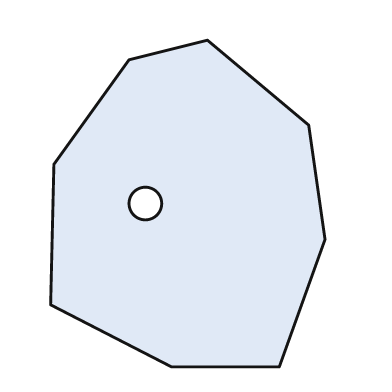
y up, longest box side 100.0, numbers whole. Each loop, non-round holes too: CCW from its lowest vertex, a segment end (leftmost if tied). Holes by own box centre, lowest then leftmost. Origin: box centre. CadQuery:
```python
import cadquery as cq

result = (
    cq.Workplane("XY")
    .moveTo(-5.0, -50.0)
    .lineTo(28.0, -50.0)
    .lineTo(42.0, -11.0)
    .lineTo(37.0, 24.0)
    .lineTo(6.0, 50.0)
    .lineTo(-18.0, 44.0)
    .lineTo(-41.0, 12.0)
    .lineTo(-42.0, -31.0)
    .close()
    .moveTo(-13.0, 0.0)
    .circle(5.0)
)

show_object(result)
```